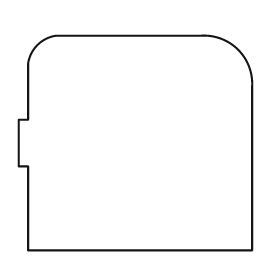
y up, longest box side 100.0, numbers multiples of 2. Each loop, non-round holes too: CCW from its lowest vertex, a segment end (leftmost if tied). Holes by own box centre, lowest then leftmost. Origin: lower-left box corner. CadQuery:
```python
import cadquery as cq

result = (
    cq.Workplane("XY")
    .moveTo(4.0, 0.0)
    .lineTo(100.0, 0.0)
    .lineTo(100.0, 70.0)
    .threePointArc((94.0, 86.0), (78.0, 92.0))
    .lineTo(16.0, 92.0)
    .threePointArc((8.0, 88.0), (4.0, 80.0))
    .lineTo(4.0, 56.0)
    .lineTo(0.0, 56.0)
    .lineTo(0.0, 36.0)
    .lineTo(4.0, 36.0)
    .close()
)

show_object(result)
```